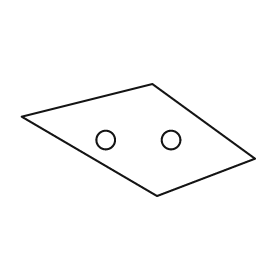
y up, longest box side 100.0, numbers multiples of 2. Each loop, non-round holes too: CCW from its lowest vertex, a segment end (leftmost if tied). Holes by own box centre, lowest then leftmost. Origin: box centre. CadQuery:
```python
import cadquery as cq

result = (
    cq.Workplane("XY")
    .moveTo(8.0, -24.0)
    .lineTo(50.0, -8.0)
    .lineTo(6.0, 24.0)
    .lineTo(-50.0, 10.0)
    .close()
    .moveTo(-14.0, 0.0)
    .circle(4.0)
    .moveTo(14.0, 0.0)
    .circle(4.0)
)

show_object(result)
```